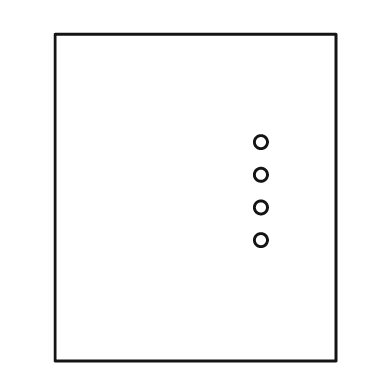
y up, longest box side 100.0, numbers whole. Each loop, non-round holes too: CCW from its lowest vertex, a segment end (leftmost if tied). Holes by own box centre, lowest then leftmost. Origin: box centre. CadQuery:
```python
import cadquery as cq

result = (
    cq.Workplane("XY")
    .moveTo(-43.0, -50.0)
    .lineTo(43.0, -50.0)
    .lineTo(43.0, 50.0)
    .lineTo(-43.0, 50.0)
    .close()
    .moveTo(20.0, -13.0)
    .circle(2.0)
    .moveTo(20.0, -3.0)
    .circle(2.0)
    .moveTo(20.0, 7.0)
    .circle(2.0)
    .moveTo(20.0, 17.0)
    .circle(2.0)
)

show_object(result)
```